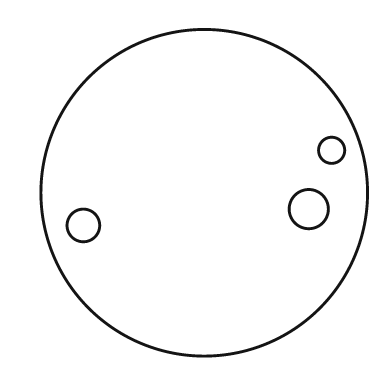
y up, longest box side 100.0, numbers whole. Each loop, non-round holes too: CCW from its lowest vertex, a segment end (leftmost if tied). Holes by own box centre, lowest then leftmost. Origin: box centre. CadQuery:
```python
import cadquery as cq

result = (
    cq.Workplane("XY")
    .moveTo(0.0, 0.0)
    .circle(50.0)
    .moveTo(-37.0, -10.0)
    .circle(5.0)
    .moveTo(32.0, -5.0)
    .circle(6.0)
    .moveTo(39.0, 13.0)
    .circle(4.0)
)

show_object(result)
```